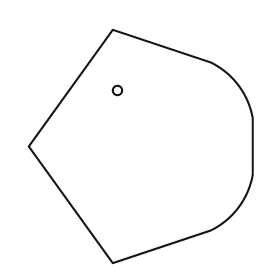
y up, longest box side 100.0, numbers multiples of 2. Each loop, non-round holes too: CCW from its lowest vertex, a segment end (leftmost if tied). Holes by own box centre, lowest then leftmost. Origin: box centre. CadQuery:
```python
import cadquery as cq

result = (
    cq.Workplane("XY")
    .moveTo(-12.0, -50.0)
    .lineTo(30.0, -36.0)
    .threePointArc((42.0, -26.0), (48.0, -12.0))
    .lineTo(48.0, 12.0)
    .threePointArc((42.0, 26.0), (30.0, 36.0))
    .lineTo(-12.0, 50.0)
    .lineTo(-48.0, 0.0)
    .close()
    .moveTo(-10.0, 24.0)
    .circle(2.0)
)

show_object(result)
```